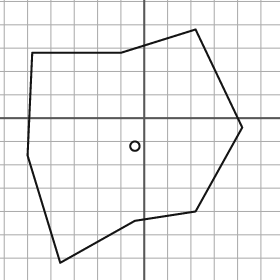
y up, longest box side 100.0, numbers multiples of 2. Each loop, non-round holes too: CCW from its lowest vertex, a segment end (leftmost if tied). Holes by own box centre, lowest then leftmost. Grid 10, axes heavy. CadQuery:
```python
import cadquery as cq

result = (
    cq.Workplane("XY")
    .moveTo(-36.0, -62.0)
    .lineTo(-4.0, -44.0)
    .lineTo(22.0, -40.0)
    .lineTo(42.0, -4.0)
    .lineTo(22.0, 38.0)
    .lineTo(-10.0, 28.0)
    .lineTo(-48.0, 28.0)
    .lineTo(-50.0, -16.0)
    .close()
    .moveTo(-4.0, -12.0)
    .circle(2.0)
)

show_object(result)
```